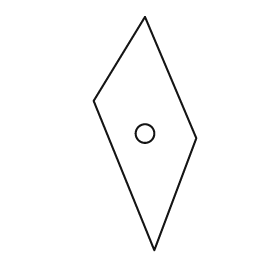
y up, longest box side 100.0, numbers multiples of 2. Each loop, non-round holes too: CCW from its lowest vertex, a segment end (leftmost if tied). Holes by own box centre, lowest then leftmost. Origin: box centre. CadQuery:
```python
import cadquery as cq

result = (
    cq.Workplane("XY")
    .moveTo(4.0, -50.0)
    .lineTo(22.0, -2.0)
    .lineTo(0.0, 50.0)
    .lineTo(-22.0, 14.0)
    .close()
    .moveTo(0.0, 0.0)
    .circle(4.0)
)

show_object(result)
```